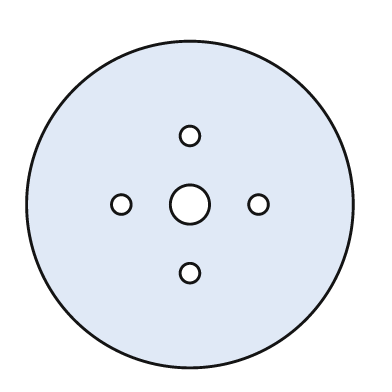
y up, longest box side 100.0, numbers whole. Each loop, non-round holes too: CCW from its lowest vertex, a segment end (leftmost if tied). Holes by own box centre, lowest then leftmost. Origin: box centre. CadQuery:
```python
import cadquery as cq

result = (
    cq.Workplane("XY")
    .moveTo(0.0, 0.0)
    .circle(50.0)
    .moveTo(0.0, -21.0)
    .circle(3.0)
    .moveTo(-21.0, 0.0)
    .circle(3.0)
    .moveTo(0.0, 0.0)
    .circle(6.0)
    .moveTo(21.0, 0.0)
    .circle(3.0)
    .moveTo(0.0, 21.0)
    .circle(3.0)
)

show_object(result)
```